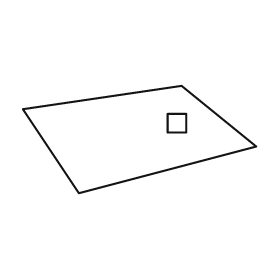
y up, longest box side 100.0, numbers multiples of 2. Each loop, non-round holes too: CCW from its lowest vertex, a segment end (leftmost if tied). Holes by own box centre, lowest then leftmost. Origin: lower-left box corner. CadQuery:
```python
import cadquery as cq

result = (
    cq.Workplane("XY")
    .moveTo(24.0, 0.0)
    .lineTo(100.0, 20.0)
    .lineTo(68.0, 46.0)
    .lineTo(0.0, 36.0)
    .close()
    .moveTo(62.0, 26.0)
    .lineTo(70.0, 26.0)
    .lineTo(70.0, 34.0)
    .lineTo(62.0, 34.0)
    .close()
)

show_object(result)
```